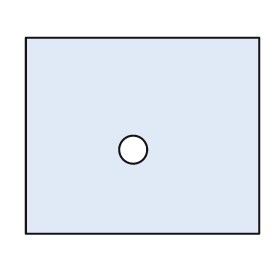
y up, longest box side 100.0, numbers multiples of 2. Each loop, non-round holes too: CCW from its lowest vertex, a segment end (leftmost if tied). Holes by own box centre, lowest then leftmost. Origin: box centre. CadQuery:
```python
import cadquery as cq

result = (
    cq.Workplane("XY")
    .moveTo(-50.0, -42.0)
    .lineTo(50.0, -42.0)
    .lineTo(50.0, 42.0)
    .lineTo(-50.0, 42.0)
    .close()
    .moveTo(-4.0, -6.0)
    .circle(6.0)
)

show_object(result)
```